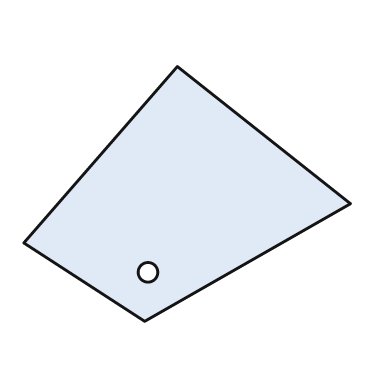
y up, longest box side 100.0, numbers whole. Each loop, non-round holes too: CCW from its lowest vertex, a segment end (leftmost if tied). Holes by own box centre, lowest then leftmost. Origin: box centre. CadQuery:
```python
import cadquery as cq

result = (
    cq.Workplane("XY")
    .moveTo(-13.0, -39.0)
    .lineTo(50.0, -3.0)
    .lineTo(-3.0, 39.0)
    .lineTo(-50.0, -15.0)
    .close()
    .moveTo(-12.0, -24.0)
    .circle(3.0)
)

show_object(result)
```